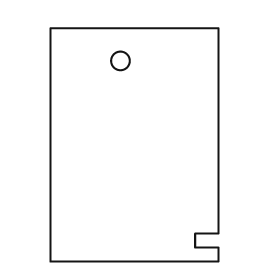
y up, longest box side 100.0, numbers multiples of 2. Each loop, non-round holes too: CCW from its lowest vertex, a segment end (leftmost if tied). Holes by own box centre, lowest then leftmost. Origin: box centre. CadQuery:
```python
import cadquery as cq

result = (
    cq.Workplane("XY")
    .moveTo(-36.0, -50.0)
    .lineTo(36.0, -50.0)
    .lineTo(36.0, -44.0)
    .lineTo(26.0, -44.0)
    .lineTo(26.0, -38.0)
    .lineTo(36.0, -38.0)
    .lineTo(36.0, 50.0)
    .lineTo(-36.0, 50.0)
    .close()
    .moveTo(-6.0, 36.0)
    .circle(4.0)
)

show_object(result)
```